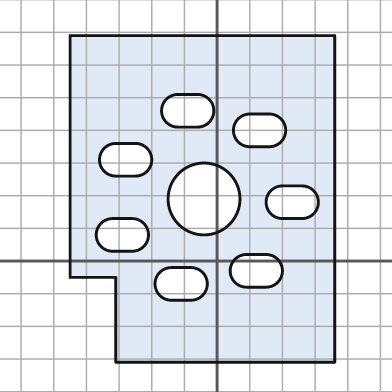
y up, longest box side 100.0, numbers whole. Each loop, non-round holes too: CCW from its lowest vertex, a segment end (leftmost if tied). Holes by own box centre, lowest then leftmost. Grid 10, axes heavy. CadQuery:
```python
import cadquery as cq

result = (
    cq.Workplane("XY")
    .moveTo(-31.0, -31.0)
    .lineTo(36.0, -31.0)
    .lineTo(36.0, 69.0)
    .lineTo(-45.0, 69.0)
    .lineTo(-45.0, -5.0)
    .lineTo(-31.0, -5.0)
    .close()
    .moveTo(-14.0, -12.0)
    .lineTo(-8.0, -12.0)
    .threePointArc((-3.0, -7.0), (-8.0, -2.0))
    .lineTo(-14.0, -2.0)
    .threePointArc((-19.0, -7.0), (-14.0, -12.0))
    .close()
    .moveTo(9.0, -8.0)
    .lineTo(15.0, -8.0)
    .threePointArc((20.0, -3.0), (15.0, 2.0))
    .lineTo(9.0, 2.0)
    .threePointArc((4.0, -3.0), (9.0, -8.0))
    .close()
    .moveTo(-32.0, 3.0)
    .lineTo(-26.0, 3.0)
    .threePointArc((-21.0, 8.0), (-26.0, 13.0))
    .lineTo(-32.0, 13.0)
    .threePointArc((-37.0, 8.0), (-32.0, 3.0))
    .close()
    .moveTo(20.0, 13.0)
    .lineTo(26.0, 13.0)
    .threePointArc((31.0, 18.0), (26.0, 23.0))
    .lineTo(20.0, 23.0)
    .threePointArc((15.0, 18.0), (20.0, 13.0))
    .close()
    .moveTo(-4.0, 19.0)
    .circle(11.0)
    .moveTo(-31.0, 26.0)
    .lineTo(-25.0, 26.0)
    .threePointArc((-20.0, 31.0), (-25.0, 36.0))
    .lineTo(-31.0, 36.0)
    .threePointArc((-36.0, 31.0), (-31.0, 26.0))
    .close()
    .moveTo(10.0, 35.0)
    .lineTo(16.0, 35.0)
    .threePointArc((21.0, 40.0), (16.0, 45.0))
    .lineTo(10.0, 45.0)
    .threePointArc((5.0, 40.0), (10.0, 35.0))
    .close()
    .moveTo(-12.0, 41.0)
    .lineTo(-6.0, 41.0)
    .threePointArc((-1.0, 46.0), (-6.0, 51.0))
    .lineTo(-12.0, 51.0)
    .threePointArc((-17.0, 46.0), (-12.0, 41.0))
    .close()
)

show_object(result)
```